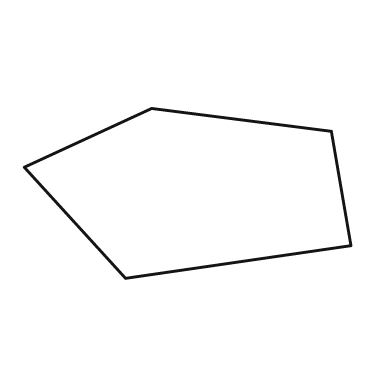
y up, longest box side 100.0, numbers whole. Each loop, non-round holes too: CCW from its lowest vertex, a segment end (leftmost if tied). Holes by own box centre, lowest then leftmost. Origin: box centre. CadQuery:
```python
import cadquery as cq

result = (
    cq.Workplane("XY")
    .moveTo(-19.0, -26.0)
    .lineTo(50.0, -16.0)
    .lineTo(44.0, 19.0)
    .lineTo(-11.0, 26.0)
    .lineTo(-50.0, 8.0)
    .close()
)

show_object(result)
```